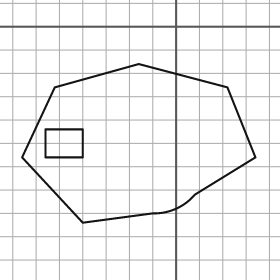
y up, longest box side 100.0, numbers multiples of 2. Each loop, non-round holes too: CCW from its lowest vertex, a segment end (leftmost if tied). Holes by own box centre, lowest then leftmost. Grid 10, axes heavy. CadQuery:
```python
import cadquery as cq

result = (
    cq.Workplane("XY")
    .moveTo(-40.0, -84.0)
    .lineTo(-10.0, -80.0)
    .threePointArc((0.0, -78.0), (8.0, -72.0))
    .lineTo(34.0, -56.0)
    .lineTo(22.0, -26.0)
    .lineTo(-16.0, -16.0)
    .lineTo(-52.0, -26.0)
    .lineTo(-66.0, -56.0)
    .close()
    .moveTo(-56.0, -56.0)
    .lineTo(-40.0, -56.0)
    .lineTo(-40.0, -44.0)
    .lineTo(-56.0, -44.0)
    .close()
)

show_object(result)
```